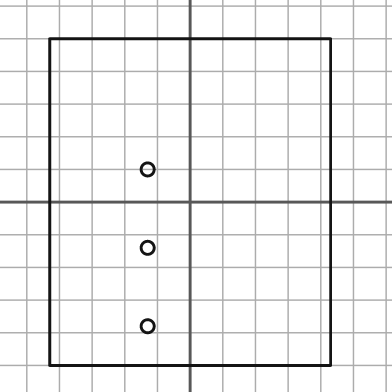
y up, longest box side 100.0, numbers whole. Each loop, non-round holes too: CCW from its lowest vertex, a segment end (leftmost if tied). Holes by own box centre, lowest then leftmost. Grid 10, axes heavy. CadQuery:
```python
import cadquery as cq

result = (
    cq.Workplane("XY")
    .moveTo(-43.0, -50.0)
    .lineTo(43.0, -50.0)
    .lineTo(43.0, 50.0)
    .lineTo(-43.0, 50.0)
    .close()
    .moveTo(-13.0, -38.0)
    .circle(2.0)
    .moveTo(-13.0, -14.0)
    .circle(2.0)
    .moveTo(-13.0, 10.0)
    .circle(2.0)
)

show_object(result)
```